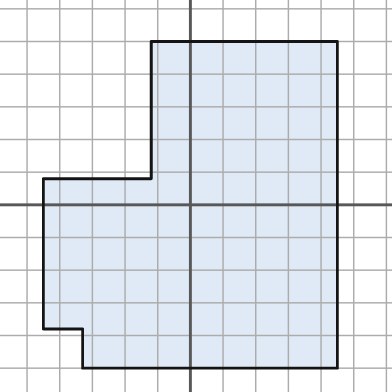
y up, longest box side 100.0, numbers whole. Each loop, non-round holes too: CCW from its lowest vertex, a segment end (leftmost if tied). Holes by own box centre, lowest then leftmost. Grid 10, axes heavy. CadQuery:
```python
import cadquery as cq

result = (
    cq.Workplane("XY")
    .moveTo(-33.0, -50.0)
    .lineTo(45.0, -50.0)
    .lineTo(45.0, 50.0)
    .lineTo(-12.0, 50.0)
    .lineTo(-12.0, 8.0)
    .lineTo(-45.0, 8.0)
    .lineTo(-45.0, -38.0)
    .lineTo(-33.0, -38.0)
    .close()
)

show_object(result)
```